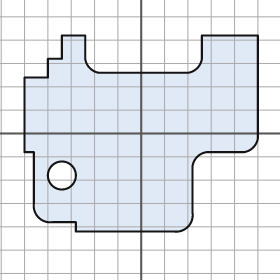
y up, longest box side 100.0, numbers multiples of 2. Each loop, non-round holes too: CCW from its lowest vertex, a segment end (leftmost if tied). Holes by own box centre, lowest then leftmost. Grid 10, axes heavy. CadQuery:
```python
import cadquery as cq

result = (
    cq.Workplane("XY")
    .moveTo(-28.0, -42.0)
    .lineTo(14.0, -42.0)
    .threePointArc((20.0, -40.0), (22.0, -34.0))
    .lineTo(22.0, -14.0)
    .threePointArc((24.0, -10.0), (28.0, -8.0))
    .lineTo(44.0, -8.0)
    .threePointArc((48.0, -6.0), (50.0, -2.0))
    .lineTo(50.0, 42.0)
    .lineTo(26.0, 42.0)
    .lineTo(26.0, 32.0)
    .threePointArc((24.0, 28.0), (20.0, 26.0))
    .lineTo(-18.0, 26.0)
    .threePointArc((-22.0, 28.0), (-24.0, 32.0))
    .lineTo(-24.0, 42.0)
    .lineTo(-34.0, 42.0)
    .lineTo(-34.0, 32.0)
    .lineTo(-40.0, 32.0)
    .lineTo(-40.0, 24.0)
    .lineTo(-50.0, 24.0)
    .lineTo(-50.0, -8.0)
    .lineTo(-46.0, -8.0)
    .lineTo(-46.0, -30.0)
    .threePointArc((-44.0, -36.0), (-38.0, -38.0))
    .lineTo(-28.0, -38.0)
    .close()
    .moveTo(-34.0, -18.0)
    .circle(6.0)
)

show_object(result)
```